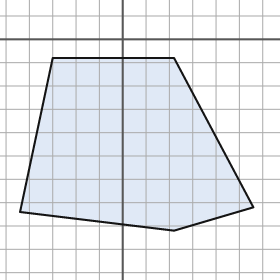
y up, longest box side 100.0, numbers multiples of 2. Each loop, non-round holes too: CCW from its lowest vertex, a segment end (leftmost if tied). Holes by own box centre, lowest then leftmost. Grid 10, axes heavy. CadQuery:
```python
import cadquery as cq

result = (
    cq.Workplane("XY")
    .moveTo(22.0, -82.0)
    .lineTo(56.0, -72.0)
    .lineTo(22.0, -8.0)
    .lineTo(-30.0, -8.0)
    .lineTo(-44.0, -74.0)
    .close()
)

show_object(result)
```